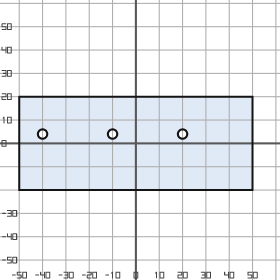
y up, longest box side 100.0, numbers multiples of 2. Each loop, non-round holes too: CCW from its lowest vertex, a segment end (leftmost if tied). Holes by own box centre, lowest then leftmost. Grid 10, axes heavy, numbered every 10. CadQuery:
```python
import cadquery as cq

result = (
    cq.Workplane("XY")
    .moveTo(-50.0, -20.0)
    .lineTo(50.0, -20.0)
    .lineTo(50.0, 20.0)
    .lineTo(-50.0, 20.0)
    .close()
    .moveTo(-40.0, 4.0)
    .circle(2.0)
    .moveTo(-10.0, 4.0)
    .circle(2.0)
    .moveTo(20.0, 4.0)
    .circle(2.0)
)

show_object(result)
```